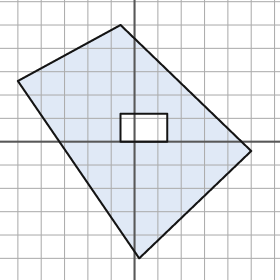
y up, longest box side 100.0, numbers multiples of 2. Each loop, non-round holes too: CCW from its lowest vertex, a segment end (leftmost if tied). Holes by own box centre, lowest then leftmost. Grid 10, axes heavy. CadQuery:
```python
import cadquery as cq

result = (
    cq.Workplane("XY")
    .moveTo(2.0, -50.0)
    .lineTo(50.0, -4.0)
    .lineTo(-6.0, 50.0)
    .lineTo(-50.0, 26.0)
    .close()
    .moveTo(-6.0, 0.0)
    .lineTo(14.0, 0.0)
    .lineTo(14.0, 12.0)
    .lineTo(-6.0, 12.0)
    .close()
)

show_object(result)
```